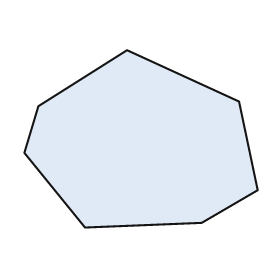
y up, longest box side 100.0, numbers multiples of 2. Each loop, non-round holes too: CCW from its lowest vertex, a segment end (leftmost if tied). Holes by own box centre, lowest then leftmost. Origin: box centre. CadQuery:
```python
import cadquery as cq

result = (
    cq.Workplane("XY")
    .moveTo(-24.0, -38.0)
    .lineTo(26.0, -36.0)
    .lineTo(50.0, -22.0)
    .lineTo(42.0, 16.0)
    .lineTo(-6.0, 38.0)
    .lineTo(-44.0, 14.0)
    .lineTo(-50.0, -6.0)
    .close()
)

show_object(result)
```